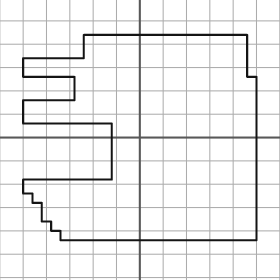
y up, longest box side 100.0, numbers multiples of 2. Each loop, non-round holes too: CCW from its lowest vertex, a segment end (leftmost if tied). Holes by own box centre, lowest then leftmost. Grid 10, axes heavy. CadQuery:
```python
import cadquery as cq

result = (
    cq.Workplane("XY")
    .moveTo(-34.0, -44.0)
    .lineTo(50.0, -44.0)
    .lineTo(50.0, 26.0)
    .lineTo(46.0, 26.0)
    .lineTo(46.0, 44.0)
    .lineTo(-24.0, 44.0)
    .lineTo(-24.0, 34.0)
    .lineTo(-50.0, 34.0)
    .lineTo(-50.0, 26.0)
    .lineTo(-28.0, 26.0)
    .lineTo(-28.0, 16.0)
    .lineTo(-50.0, 16.0)
    .lineTo(-50.0, 6.0)
    .lineTo(-12.0, 6.0)
    .lineTo(-12.0, -18.0)
    .lineTo(-50.0, -18.0)
    .lineTo(-50.0, -24.0)
    .lineTo(-46.0, -24.0)
    .lineTo(-46.0, -28.0)
    .lineTo(-42.0, -28.0)
    .lineTo(-42.0, -36.0)
    .lineTo(-38.0, -36.0)
    .lineTo(-38.0, -40.0)
    .lineTo(-34.0, -40.0)
    .close()
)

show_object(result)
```